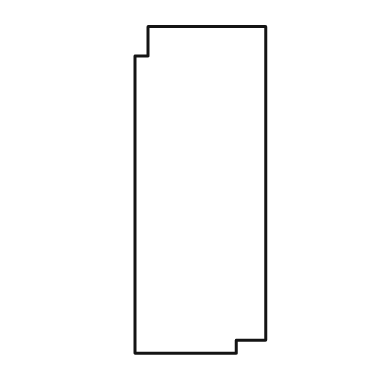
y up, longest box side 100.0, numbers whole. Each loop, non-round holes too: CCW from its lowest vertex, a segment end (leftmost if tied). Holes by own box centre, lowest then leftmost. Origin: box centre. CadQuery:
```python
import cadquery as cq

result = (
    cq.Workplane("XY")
    .moveTo(-20.0, -50.0)
    .lineTo(11.0, -50.0)
    .lineTo(11.0, -46.0)
    .lineTo(20.0, -46.0)
    .lineTo(20.0, 50.0)
    .lineTo(-16.0, 50.0)
    .lineTo(-16.0, 41.0)
    .lineTo(-20.0, 41.0)
    .close()
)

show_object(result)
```